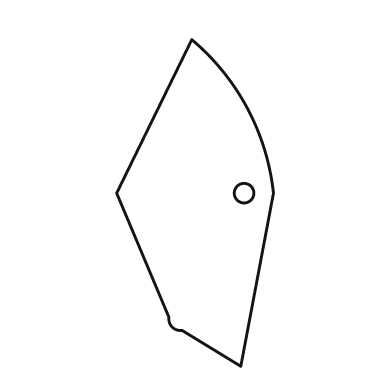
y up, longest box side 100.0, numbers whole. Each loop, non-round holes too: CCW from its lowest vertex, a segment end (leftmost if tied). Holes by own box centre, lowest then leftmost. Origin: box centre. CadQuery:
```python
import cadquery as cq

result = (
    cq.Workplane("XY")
    .moveTo(14.0, -50.0)
    .lineTo(24.0, 3.0)
    .threePointArc((16.0, 29.0), (-1.0, 50.0))
    .lineTo(-24.0, 3.0)
    .lineTo(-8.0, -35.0)
    .threePointArc((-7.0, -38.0), (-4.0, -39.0))
    .close()
    .moveTo(15.0, 3.0)
    .circle(3.0)
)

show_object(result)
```